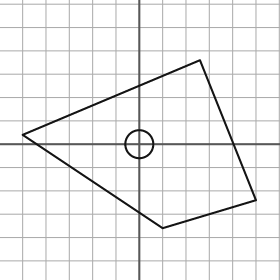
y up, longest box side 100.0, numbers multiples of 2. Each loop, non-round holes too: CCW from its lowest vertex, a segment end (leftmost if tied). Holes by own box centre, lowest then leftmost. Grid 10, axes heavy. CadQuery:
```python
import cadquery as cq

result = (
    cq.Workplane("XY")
    .moveTo(10.0, -36.0)
    .lineTo(50.0, -24.0)
    .lineTo(26.0, 36.0)
    .lineTo(-50.0, 4.0)
    .close()
    .moveTo(0.0, 0.0)
    .circle(6.0)
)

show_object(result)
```